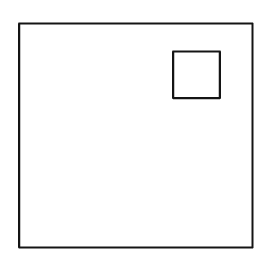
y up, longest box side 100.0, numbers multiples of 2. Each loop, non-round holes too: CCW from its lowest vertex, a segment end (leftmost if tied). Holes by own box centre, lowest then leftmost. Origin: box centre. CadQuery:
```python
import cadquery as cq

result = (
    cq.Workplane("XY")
    .moveTo(-50.0, -48.0)
    .lineTo(50.0, -48.0)
    .lineTo(50.0, 48.0)
    .lineTo(-50.0, 48.0)
    .close()
    .moveTo(16.0, 16.0)
    .lineTo(36.0, 16.0)
    .lineTo(36.0, 36.0)
    .lineTo(16.0, 36.0)
    .close()
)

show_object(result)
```